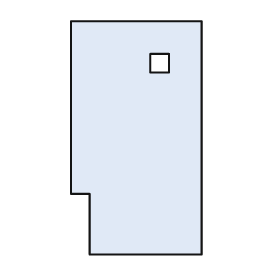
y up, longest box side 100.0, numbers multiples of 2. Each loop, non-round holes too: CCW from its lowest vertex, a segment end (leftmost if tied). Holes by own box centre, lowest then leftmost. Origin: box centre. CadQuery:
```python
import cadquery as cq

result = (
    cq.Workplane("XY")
    .moveTo(-20.0, -50.0)
    .lineTo(28.0, -50.0)
    .lineTo(28.0, 50.0)
    .lineTo(-28.0, 50.0)
    .lineTo(-28.0, -24.0)
    .lineTo(-20.0, -24.0)
    .close()
    .moveTo(6.0, 28.0)
    .lineTo(14.0, 28.0)
    .lineTo(14.0, 36.0)
    .lineTo(6.0, 36.0)
    .close()
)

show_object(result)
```